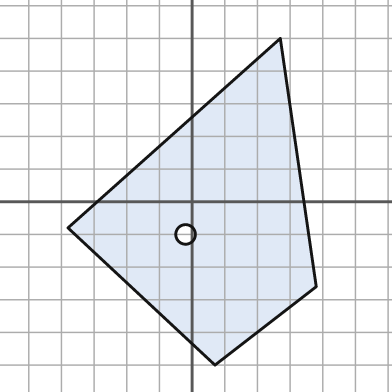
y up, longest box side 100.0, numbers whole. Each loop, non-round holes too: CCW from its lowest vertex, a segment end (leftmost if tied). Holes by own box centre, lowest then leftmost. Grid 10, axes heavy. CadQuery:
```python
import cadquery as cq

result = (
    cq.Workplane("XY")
    .moveTo(7.0, -50.0)
    .lineTo(38.0, -26.0)
    .lineTo(27.0, 50.0)
    .lineTo(-38.0, -8.0)
    .close()
    .moveTo(-2.0, -10.0)
    .circle(3.0)
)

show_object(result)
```